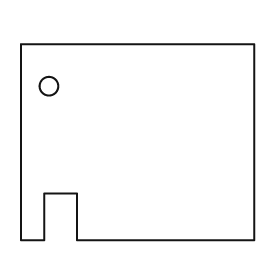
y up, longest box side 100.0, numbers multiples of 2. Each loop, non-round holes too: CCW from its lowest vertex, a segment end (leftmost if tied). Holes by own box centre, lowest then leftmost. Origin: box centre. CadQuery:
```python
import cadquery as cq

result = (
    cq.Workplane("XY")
    .moveTo(-50.0, -42.0)
    .lineTo(-40.0, -42.0)
    .lineTo(-40.0, -22.0)
    .lineTo(-26.0, -22.0)
    .lineTo(-26.0, -42.0)
    .lineTo(50.0, -42.0)
    .lineTo(50.0, 42.0)
    .lineTo(-50.0, 42.0)
    .close()
    .moveTo(-38.0, 24.0)
    .circle(4.0)
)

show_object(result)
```